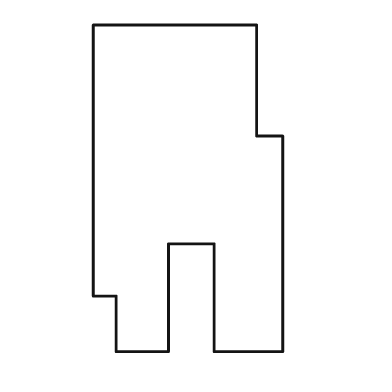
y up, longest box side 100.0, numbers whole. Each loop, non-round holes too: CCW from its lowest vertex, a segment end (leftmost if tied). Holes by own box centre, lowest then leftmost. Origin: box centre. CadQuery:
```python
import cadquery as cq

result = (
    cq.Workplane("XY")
    .moveTo(-22.0, -50.0)
    .lineTo(-6.0, -50.0)
    .lineTo(-6.0, -17.0)
    .lineTo(8.0, -17.0)
    .lineTo(8.0, -50.0)
    .lineTo(29.0, -50.0)
    .lineTo(29.0, 16.0)
    .lineTo(21.0, 16.0)
    .lineTo(21.0, 50.0)
    .lineTo(-29.0, 50.0)
    .lineTo(-29.0, -33.0)
    .lineTo(-22.0, -33.0)
    .close()
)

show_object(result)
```